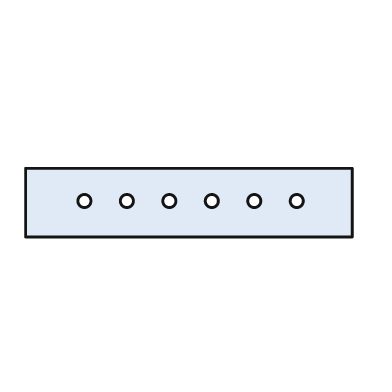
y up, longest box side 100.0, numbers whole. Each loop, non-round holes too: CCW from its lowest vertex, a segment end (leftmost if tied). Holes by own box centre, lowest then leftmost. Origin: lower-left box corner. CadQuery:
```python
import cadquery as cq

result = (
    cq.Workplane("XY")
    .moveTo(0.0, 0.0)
    .lineTo(100.0, 0.0)
    .lineTo(100.0, 21.0)
    .lineTo(0.0, 21.0)
    .close()
    .moveTo(18.0, 11.0)
    .circle(2.0)
    .moveTo(31.0, 11.0)
    .circle(2.0)
    .moveTo(44.0, 11.0)
    .circle(2.0)
    .moveTo(57.0, 11.0)
    .circle(2.0)
    .moveTo(70.0, 11.0)
    .circle(2.0)
    .moveTo(83.0, 11.0)
    .circle(2.0)
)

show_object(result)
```